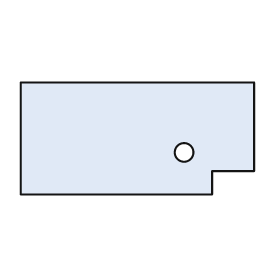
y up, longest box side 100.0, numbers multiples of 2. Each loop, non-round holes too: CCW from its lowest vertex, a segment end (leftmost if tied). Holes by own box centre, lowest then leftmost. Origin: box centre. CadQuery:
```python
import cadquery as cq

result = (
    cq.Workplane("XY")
    .moveTo(-50.0, -24.0)
    .lineTo(32.0, -24.0)
    .lineTo(32.0, -14.0)
    .lineTo(50.0, -14.0)
    .lineTo(50.0, 24.0)
    .lineTo(-50.0, 24.0)
    .close()
    .moveTo(20.0, -6.0)
    .circle(4.0)
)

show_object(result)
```